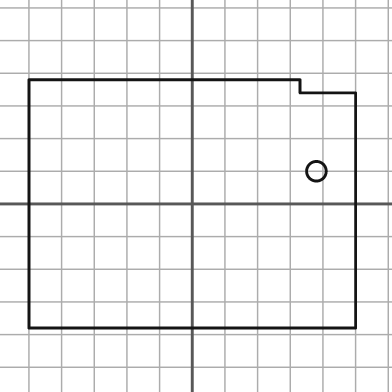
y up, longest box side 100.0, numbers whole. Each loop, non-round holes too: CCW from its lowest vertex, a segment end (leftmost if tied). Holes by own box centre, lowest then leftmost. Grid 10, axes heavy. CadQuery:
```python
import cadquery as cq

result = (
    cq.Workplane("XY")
    .moveTo(-50.0, -38.0)
    .lineTo(50.0, -38.0)
    .lineTo(50.0, 34.0)
    .lineTo(33.0, 34.0)
    .lineTo(33.0, 38.0)
    .lineTo(-50.0, 38.0)
    .close()
    .moveTo(38.0, 10.0)
    .circle(3.0)
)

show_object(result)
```